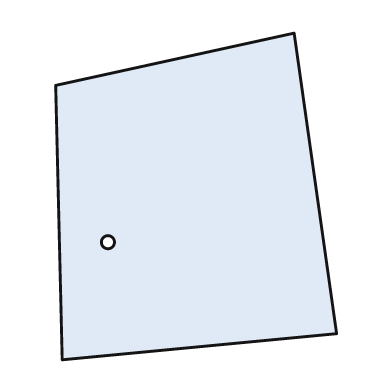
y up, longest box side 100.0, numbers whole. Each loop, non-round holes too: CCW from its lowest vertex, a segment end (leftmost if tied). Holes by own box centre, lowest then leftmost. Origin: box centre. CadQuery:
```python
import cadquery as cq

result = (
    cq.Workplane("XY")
    .moveTo(-41.0, -50.0)
    .lineTo(43.0, -42.0)
    .lineTo(30.0, 50.0)
    .lineTo(-43.0, 34.0)
    .close()
    .moveTo(-27.0, -14.0)
    .circle(2.0)
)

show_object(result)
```